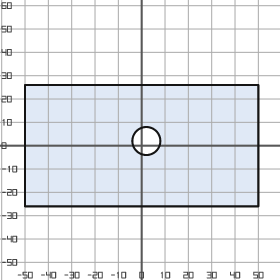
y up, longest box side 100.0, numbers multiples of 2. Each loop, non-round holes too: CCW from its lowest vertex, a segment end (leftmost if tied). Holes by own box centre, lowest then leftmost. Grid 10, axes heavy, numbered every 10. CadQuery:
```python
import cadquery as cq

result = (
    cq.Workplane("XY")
    .moveTo(-50.0, -26.0)
    .lineTo(50.0, -26.0)
    .lineTo(50.0, 26.0)
    .lineTo(-50.0, 26.0)
    .close()
    .moveTo(2.0, 2.0)
    .circle(6.0)
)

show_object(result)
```